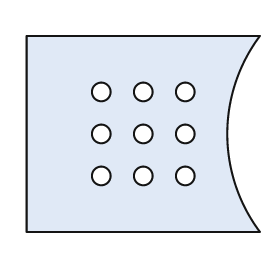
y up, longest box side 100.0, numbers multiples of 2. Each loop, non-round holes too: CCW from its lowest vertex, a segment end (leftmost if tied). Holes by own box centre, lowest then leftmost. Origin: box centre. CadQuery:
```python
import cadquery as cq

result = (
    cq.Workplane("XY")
    .moveTo(-50.0, -42.0)
    .lineTo(50.0, -42.0)
    .threePointArc((36.0, 0.0), (50.0, 42.0))
    .lineTo(-50.0, 42.0)
    .close()
    .moveTo(-18.0, -18.0)
    .circle(4.0)
    .moveTo(0.0, -18.0)
    .circle(4.0)
    .moveTo(18.0, -18.0)
    .circle(4.0)
    .moveTo(-18.0, 0.0)
    .circle(4.0)
    .moveTo(0.0, 0.0)
    .circle(4.0)
    .moveTo(18.0, 0.0)
    .circle(4.0)
    .moveTo(-18.0, 18.0)
    .circle(4.0)
    .moveTo(0.0, 18.0)
    .circle(4.0)
    .moveTo(18.0, 18.0)
    .circle(4.0)
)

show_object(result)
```